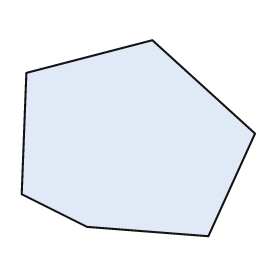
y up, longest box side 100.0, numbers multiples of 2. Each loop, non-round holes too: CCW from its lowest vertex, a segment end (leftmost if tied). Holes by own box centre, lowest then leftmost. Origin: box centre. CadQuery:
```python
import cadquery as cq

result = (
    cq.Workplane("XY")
    .moveTo(30.0, -42.0)
    .lineTo(50.0, 2.0)
    .lineTo(6.0, 42.0)
    .lineTo(-48.0, 28.0)
    .lineTo(-50.0, -24.0)
    .lineTo(-22.0, -38.0)
    .close()
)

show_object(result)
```